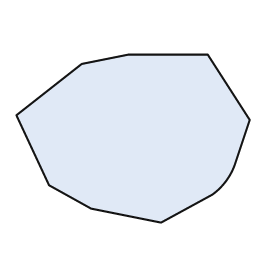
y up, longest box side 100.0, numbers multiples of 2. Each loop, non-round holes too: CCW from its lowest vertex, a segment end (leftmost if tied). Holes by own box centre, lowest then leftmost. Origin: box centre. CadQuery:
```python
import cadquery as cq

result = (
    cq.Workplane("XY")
    .moveTo(12.0, -36.0)
    .lineTo(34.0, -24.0)
    .threePointArc((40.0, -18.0), (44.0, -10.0))
    .lineTo(50.0, 8.0)
    .lineTo(32.0, 36.0)
    .lineTo(-2.0, 36.0)
    .lineTo(-22.0, 32.0)
    .lineTo(-50.0, 10.0)
    .lineTo(-36.0, -20.0)
    .lineTo(-18.0, -30.0)
    .close()
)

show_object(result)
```